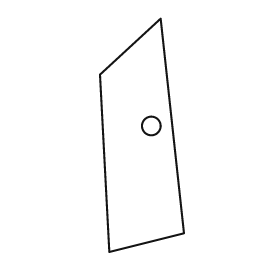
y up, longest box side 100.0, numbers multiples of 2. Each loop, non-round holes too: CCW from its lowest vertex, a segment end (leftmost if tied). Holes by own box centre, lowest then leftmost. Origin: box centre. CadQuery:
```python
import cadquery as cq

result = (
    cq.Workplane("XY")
    .moveTo(-14.0, -50.0)
    .lineTo(18.0, -42.0)
    .lineTo(8.0, 50.0)
    .lineTo(-18.0, 26.0)
    .close()
    .moveTo(4.0, 4.0)
    .circle(4.0)
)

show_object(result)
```